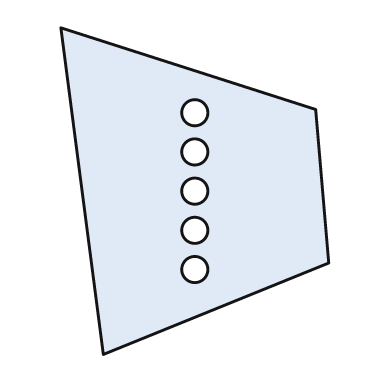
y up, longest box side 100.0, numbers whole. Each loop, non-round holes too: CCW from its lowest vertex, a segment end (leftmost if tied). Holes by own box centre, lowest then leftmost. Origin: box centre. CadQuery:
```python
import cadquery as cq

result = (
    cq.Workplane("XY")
    .moveTo(-28.0, -50.0)
    .lineTo(41.0, -22.0)
    .lineTo(37.0, 25.0)
    .lineTo(-41.0, 50.0)
    .close()
    .moveTo(0.0, -24.0)
    .circle(4.0)
    .moveTo(0.0, -12.0)
    .circle(4.0)
    .moveTo(0.0, 0.0)
    .circle(4.0)
    .moveTo(0.0, 12.0)
    .circle(4.0)
    .moveTo(0.0, 24.0)
    .circle(4.0)
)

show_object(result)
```